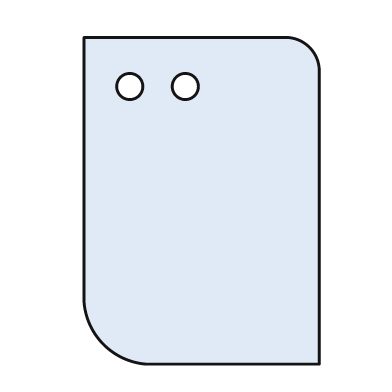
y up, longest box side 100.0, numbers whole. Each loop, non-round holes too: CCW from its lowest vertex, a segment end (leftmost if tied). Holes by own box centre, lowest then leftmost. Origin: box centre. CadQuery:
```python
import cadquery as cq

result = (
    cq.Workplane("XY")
    .moveTo(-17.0, -50.0)
    .lineTo(36.0, -50.0)
    .lineTo(36.0, 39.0)
    .threePointArc((33.0, 47.0), (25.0, 50.0))
    .lineTo(-36.0, 50.0)
    .lineTo(-36.0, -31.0)
    .threePointArc((-30.0, -44.0), (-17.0, -50.0))
    .close()
    .moveTo(-22.0, 35.0)
    .circle(4.0)
    .moveTo(-5.0, 35.0)
    .circle(4.0)
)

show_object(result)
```